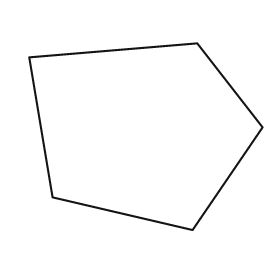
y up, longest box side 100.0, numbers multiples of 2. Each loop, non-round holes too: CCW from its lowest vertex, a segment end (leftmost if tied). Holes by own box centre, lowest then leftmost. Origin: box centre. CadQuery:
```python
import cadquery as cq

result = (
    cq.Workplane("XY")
    .moveTo(20.0, -40.0)
    .lineTo(50.0, 4.0)
    .lineTo(22.0, 40.0)
    .lineTo(-50.0, 34.0)
    .lineTo(-40.0, -26.0)
    .close()
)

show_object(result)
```